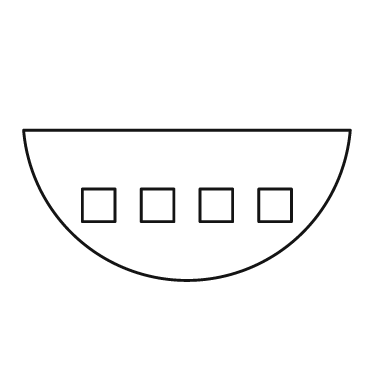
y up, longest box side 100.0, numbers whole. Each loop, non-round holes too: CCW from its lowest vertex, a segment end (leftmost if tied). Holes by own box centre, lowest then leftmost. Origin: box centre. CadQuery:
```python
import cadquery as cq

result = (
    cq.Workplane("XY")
    .moveTo(-50.0, 23.0)
    .threePointArc((0.0, -23.0), (50.0, 23.0))
    .close()
    .moveTo(-32.0, -5.0)
    .lineTo(-22.0, -5.0)
    .lineTo(-22.0, 5.0)
    .lineTo(-32.0, 5.0)
    .close()
    .moveTo(-14.0, -5.0)
    .lineTo(-4.0, -5.0)
    .lineTo(-4.0, 5.0)
    .lineTo(-14.0, 5.0)
    .close()
    .moveTo(4.0, -5.0)
    .lineTo(14.0, -5.0)
    .lineTo(14.0, 5.0)
    .lineTo(4.0, 5.0)
    .close()
    .moveTo(22.0, -5.0)
    .lineTo(32.0, -5.0)
    .lineTo(32.0, 5.0)
    .lineTo(22.0, 5.0)
    .close()
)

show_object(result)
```